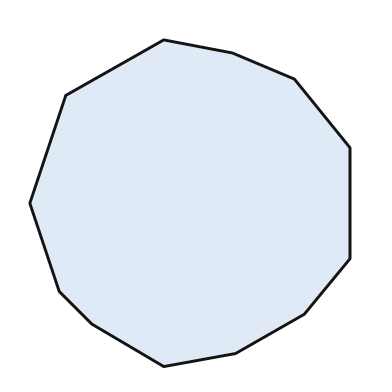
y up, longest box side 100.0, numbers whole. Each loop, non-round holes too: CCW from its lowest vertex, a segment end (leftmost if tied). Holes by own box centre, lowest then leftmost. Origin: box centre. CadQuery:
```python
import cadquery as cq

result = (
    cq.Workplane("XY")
    .moveTo(-8.0, -50.0)
    .lineTo(14.0, -46.0)
    .lineTo(35.0, -34.0)
    .lineTo(49.0, -17.0)
    .lineTo(49.0, 17.0)
    .lineTo(32.0, 38.0)
    .lineTo(13.0, 46.0)
    .lineTo(-8.0, 50.0)
    .lineTo(-38.0, 33.0)
    .lineTo(-49.0, 0.0)
    .lineTo(-40.0, -27.0)
    .lineTo(-30.0, -37.0)
    .close()
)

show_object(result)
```